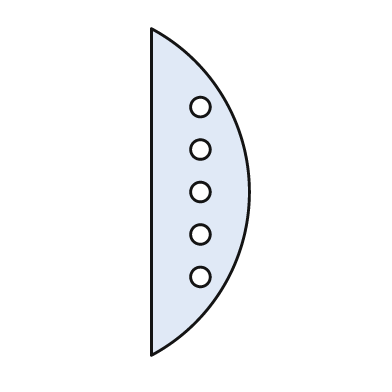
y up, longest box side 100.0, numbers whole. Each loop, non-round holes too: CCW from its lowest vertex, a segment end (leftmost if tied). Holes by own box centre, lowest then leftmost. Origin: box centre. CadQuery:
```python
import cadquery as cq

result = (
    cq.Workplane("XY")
    .moveTo(-15.0, -50.0)
    .threePointArc((15.0, 0.0), (-15.0, 50.0))
    .close()
    .moveTo(0.0, -26.0)
    .circle(3.0)
    .moveTo(0.0, -13.0)
    .circle(3.0)
    .moveTo(0.0, 0.0)
    .circle(3.0)
    .moveTo(0.0, 13.0)
    .circle(3.0)
    .moveTo(0.0, 26.0)
    .circle(3.0)
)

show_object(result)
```